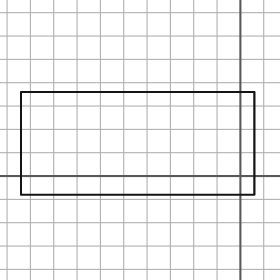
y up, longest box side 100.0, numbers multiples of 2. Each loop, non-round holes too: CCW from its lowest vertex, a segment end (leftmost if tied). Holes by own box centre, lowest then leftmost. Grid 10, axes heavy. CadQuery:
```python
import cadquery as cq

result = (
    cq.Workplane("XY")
    .moveTo(-94.0, -8.0)
    .lineTo(6.0, -8.0)
    .lineTo(6.0, 36.0)
    .lineTo(-94.0, 36.0)
    .close()
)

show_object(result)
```